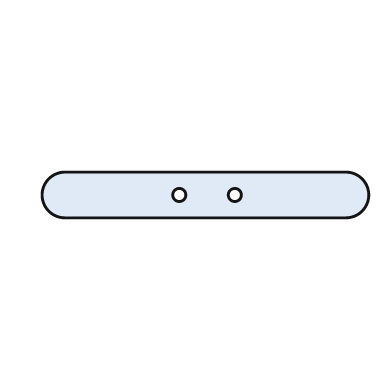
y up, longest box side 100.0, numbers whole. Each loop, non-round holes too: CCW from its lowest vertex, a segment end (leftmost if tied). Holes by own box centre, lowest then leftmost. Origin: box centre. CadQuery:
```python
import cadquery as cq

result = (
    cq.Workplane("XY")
    .moveTo(-43.0, -7.0)
    .lineTo(43.0, -7.0)
    .threePointArc((50.0, 0.0), (43.0, 7.0))
    .lineTo(-43.0, 7.0)
    .threePointArc((-50.0, 0.0), (-43.0, -7.0))
    .close()
    .moveTo(-8.0, 0.0)
    .circle(2.0)
    .moveTo(9.0, 0.0)
    .circle(2.0)
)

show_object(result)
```